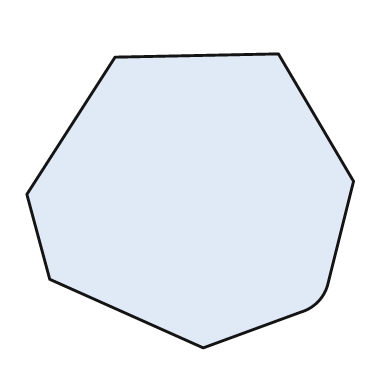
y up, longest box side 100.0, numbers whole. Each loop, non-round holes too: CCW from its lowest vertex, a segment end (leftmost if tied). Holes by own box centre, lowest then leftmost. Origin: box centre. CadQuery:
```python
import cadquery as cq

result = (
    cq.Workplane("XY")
    .moveTo(4.0, -45.0)
    .lineTo(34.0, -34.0)
    .threePointArc((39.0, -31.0), (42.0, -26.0))
    .lineTo(50.0, 6.0)
    .lineTo(27.0, 45.0)
    .lineTo(-23.0, 44.0)
    .lineTo(-50.0, 2.0)
    .lineTo(-43.0, -24.0)
    .close()
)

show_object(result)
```